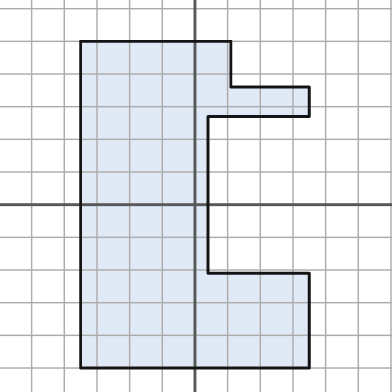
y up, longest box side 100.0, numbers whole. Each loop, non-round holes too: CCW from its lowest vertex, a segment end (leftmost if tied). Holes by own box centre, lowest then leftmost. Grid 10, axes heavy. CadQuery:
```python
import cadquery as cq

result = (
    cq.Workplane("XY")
    .moveTo(-35.0, -50.0)
    .lineTo(35.0, -50.0)
    .lineTo(35.0, -21.0)
    .lineTo(4.0, -21.0)
    .lineTo(4.0, 27.0)
    .lineTo(35.0, 27.0)
    .lineTo(35.0, 36.0)
    .lineTo(11.0, 36.0)
    .lineTo(11.0, 50.0)
    .lineTo(-35.0, 50.0)
    .close()
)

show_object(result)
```